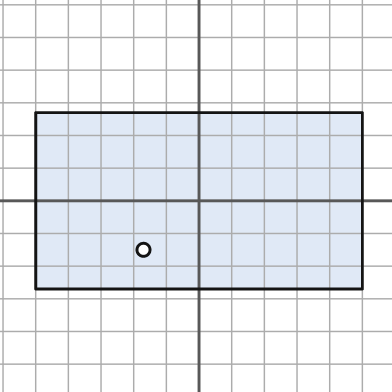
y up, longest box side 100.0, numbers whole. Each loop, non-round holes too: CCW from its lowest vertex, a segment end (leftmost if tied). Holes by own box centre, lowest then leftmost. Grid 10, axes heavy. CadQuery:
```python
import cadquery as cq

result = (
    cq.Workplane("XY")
    .moveTo(-50.0, -27.0)
    .lineTo(50.0, -27.0)
    .lineTo(50.0, 27.0)
    .lineTo(-50.0, 27.0)
    .close()
    .moveTo(-17.0, -15.0)
    .circle(2.0)
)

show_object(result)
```